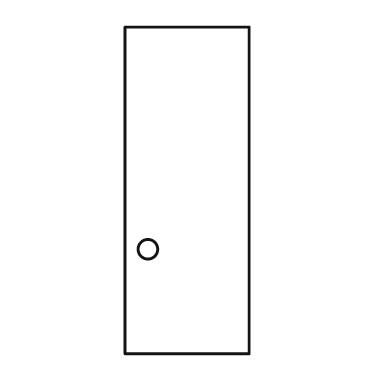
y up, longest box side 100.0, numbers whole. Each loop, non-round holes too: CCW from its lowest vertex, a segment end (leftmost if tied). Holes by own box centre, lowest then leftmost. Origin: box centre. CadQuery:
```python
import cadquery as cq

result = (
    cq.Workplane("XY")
    .moveTo(-19.0, -50.0)
    .lineTo(19.0, -50.0)
    .lineTo(19.0, 50.0)
    .lineTo(-19.0, 50.0)
    .close()
    .moveTo(-12.0, -18.0)
    .circle(3.0)
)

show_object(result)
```